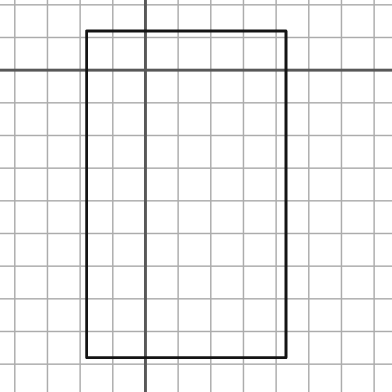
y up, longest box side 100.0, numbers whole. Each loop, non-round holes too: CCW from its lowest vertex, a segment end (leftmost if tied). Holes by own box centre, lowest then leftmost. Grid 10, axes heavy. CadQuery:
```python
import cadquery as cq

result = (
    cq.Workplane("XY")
    .moveTo(-18.0, -88.0)
    .lineTo(43.0, -88.0)
    .lineTo(43.0, 12.0)
    .lineTo(-18.0, 12.0)
    .close()
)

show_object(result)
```